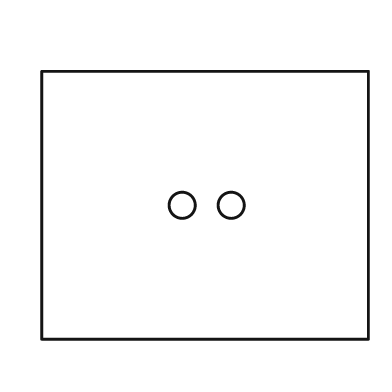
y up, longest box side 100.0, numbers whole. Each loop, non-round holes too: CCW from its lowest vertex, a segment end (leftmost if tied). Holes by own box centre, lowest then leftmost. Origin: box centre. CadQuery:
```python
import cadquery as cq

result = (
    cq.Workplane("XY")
    .moveTo(-50.0, -41.0)
    .lineTo(50.0, -41.0)
    .lineTo(50.0, 41.0)
    .lineTo(-50.0, 41.0)
    .close()
    .moveTo(-7.0, 0.0)
    .circle(4.0)
    .moveTo(8.0, 0.0)
    .circle(4.0)
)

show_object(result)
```